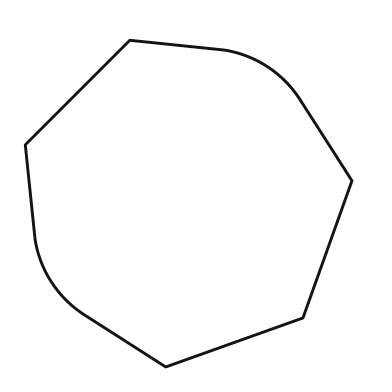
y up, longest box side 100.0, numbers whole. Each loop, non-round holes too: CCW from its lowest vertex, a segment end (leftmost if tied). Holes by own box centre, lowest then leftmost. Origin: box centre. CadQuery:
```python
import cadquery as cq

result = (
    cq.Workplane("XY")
    .moveTo(-7.0, -50.0)
    .lineTo(35.0, -35.0)
    .lineTo(50.0, 7.0)
    .lineTo(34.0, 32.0)
    .threePointArc((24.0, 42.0), (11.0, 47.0))
    .lineTo(-18.0, 50.0)
    .lineTo(-50.0, 18.0)
    .lineTo(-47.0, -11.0)
    .threePointArc((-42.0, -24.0), (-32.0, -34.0))
    .close()
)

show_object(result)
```